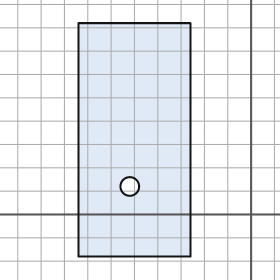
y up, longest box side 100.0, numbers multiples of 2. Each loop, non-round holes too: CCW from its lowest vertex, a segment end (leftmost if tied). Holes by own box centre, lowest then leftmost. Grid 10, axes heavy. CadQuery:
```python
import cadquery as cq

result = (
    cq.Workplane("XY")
    .moveTo(-74.0, -18.0)
    .lineTo(-26.0, -18.0)
    .lineTo(-26.0, 82.0)
    .lineTo(-74.0, 82.0)
    .close()
    .moveTo(-52.0, 12.0)
    .circle(4.0)
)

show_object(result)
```